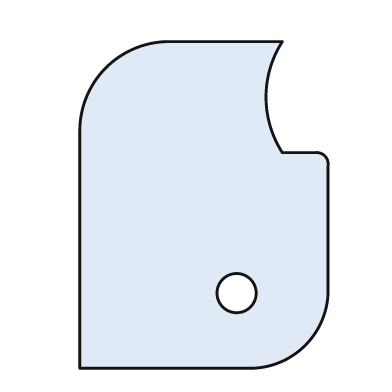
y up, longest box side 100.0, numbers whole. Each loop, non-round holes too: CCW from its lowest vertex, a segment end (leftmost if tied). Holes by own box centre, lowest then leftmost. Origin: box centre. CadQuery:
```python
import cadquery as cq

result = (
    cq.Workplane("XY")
    .moveTo(-38.0, -50.0)
    .lineTo(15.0, -50.0)
    .threePointArc((31.0, -43.0), (38.0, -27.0))
    .lineTo(38.0, 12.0)
    .threePointArc((37.0, 15.0), (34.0, 16.0))
    .lineTo(24.0, 16.0)
    .threePointArc((19.0, 33.0), (24.0, 50.0))
    .lineTo(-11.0, 50.0)
    .threePointArc((-30.0, 42.0), (-38.0, 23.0))
    .close()
    .moveTo(10.0, -27.0)
    .circle(6.0)
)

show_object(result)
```